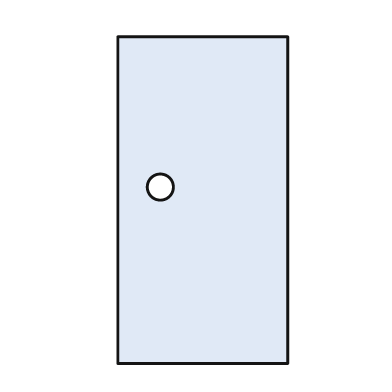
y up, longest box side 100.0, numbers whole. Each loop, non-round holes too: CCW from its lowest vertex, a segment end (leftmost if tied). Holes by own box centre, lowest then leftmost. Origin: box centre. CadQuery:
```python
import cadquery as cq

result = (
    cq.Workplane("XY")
    .moveTo(-26.0, -50.0)
    .lineTo(26.0, -50.0)
    .lineTo(26.0, 50.0)
    .lineTo(-26.0, 50.0)
    .close()
    .moveTo(-13.0, 4.0)
    .circle(4.0)
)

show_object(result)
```